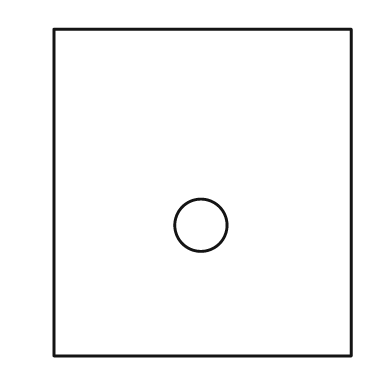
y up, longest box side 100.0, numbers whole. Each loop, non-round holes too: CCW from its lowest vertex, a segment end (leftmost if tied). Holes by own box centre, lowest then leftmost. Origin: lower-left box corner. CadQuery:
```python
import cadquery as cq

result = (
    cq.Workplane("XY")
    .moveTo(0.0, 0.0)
    .lineTo(91.0, 0.0)
    .lineTo(91.0, 100.0)
    .lineTo(0.0, 100.0)
    .close()
    .moveTo(45.0, 40.0)
    .circle(8.0)
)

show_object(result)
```